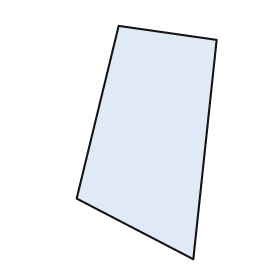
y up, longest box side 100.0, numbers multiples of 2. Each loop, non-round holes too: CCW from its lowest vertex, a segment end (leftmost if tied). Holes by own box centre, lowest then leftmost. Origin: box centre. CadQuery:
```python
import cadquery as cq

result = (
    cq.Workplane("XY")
    .moveTo(20.0, -50.0)
    .lineTo(30.0, 44.0)
    .lineTo(-12.0, 50.0)
    .lineTo(-30.0, -24.0)
    .close()
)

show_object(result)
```